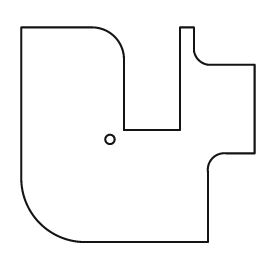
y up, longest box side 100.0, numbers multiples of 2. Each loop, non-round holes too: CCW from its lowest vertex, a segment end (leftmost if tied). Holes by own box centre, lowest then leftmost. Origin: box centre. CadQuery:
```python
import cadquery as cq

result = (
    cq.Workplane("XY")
    .moveTo(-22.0, -46.0)
    .lineTo(30.0, -46.0)
    .lineTo(30.0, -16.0)
    .threePointArc((32.0, -10.0), (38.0, -8.0))
    .lineTo(50.0, -8.0)
    .lineTo(50.0, 30.0)
    .lineTo(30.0, 30.0)
    .threePointArc((26.0, 32.0), (24.0, 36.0))
    .lineTo(24.0, 46.0)
    .lineTo(18.0, 46.0)
    .lineTo(18.0, 2.0)
    .lineTo(-6.0, 2.0)
    .lineTo(-6.0, 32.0)
    .threePointArc((-10.0, 42.0), (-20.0, 46.0))
    .lineTo(-50.0, 46.0)
    .lineTo(-50.0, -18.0)
    .threePointArc((-42.0, -38.0), (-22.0, -46.0))
    .close()
    .moveTo(-12.0, -2.0)
    .circle(2.0)
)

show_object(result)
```